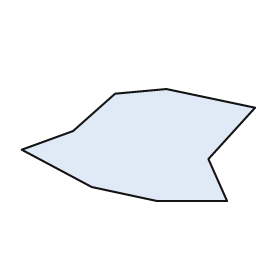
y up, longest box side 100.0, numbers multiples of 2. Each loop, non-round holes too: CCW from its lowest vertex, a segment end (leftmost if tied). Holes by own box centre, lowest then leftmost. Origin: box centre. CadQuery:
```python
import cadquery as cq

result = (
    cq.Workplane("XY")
    .moveTo(8.0, -24.0)
    .lineTo(38.0, -24.0)
    .lineTo(30.0, -6.0)
    .lineTo(50.0, 16.0)
    .lineTo(12.0, 24.0)
    .lineTo(-10.0, 22.0)
    .lineTo(-28.0, 6.0)
    .lineTo(-50.0, -2.0)
    .lineTo(-20.0, -18.0)
    .close()
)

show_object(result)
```